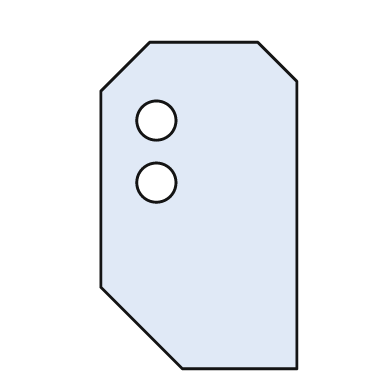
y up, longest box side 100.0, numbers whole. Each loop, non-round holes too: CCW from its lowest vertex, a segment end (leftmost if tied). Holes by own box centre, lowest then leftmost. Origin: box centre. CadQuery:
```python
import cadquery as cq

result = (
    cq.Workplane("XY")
    .moveTo(-5.0, -50.0)
    .lineTo(30.0, -50.0)
    .lineTo(30.0, 38.0)
    .lineTo(18.0, 50.0)
    .lineTo(-15.0, 50.0)
    .lineTo(-30.0, 35.0)
    .lineTo(-30.0, -25.0)
    .close()
    .moveTo(-13.0, 7.0)
    .circle(6.0)
    .moveTo(-13.0, 26.0)
    .circle(6.0)
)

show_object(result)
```